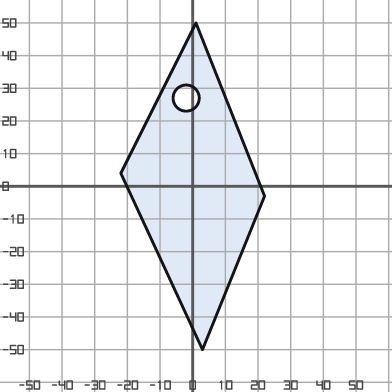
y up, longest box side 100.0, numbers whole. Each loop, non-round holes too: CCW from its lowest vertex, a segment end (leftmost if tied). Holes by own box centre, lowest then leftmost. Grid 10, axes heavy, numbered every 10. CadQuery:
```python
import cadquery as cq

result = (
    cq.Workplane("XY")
    .moveTo(3.0, -50.0)
    .lineTo(22.0, -3.0)
    .lineTo(1.0, 50.0)
    .lineTo(-22.0, 4.0)
    .close()
    .moveTo(-2.0, 27.0)
    .circle(4.0)
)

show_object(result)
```